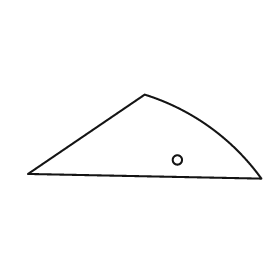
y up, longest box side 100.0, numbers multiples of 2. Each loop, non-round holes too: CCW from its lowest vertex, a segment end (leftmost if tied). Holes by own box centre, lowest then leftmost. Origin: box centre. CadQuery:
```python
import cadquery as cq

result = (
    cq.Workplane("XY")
    .moveTo(50.0, -18.0)
    .threePointArc((28.0, 4.0), (0.0, 18.0))
    .lineTo(-50.0, -16.0)
    .close()
    .moveTo(14.0, -10.0)
    .circle(2.0)
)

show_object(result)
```